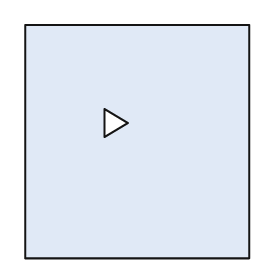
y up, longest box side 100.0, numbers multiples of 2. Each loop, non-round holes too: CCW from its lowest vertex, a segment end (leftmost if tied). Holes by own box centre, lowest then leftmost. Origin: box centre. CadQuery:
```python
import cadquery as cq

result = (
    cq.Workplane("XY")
    .moveTo(-48.0, -50.0)
    .lineTo(48.0, -50.0)
    .lineTo(48.0, 50.0)
    .lineTo(-48.0, 50.0)
    .close()
    .moveTo(-14.0, 2.0)
    .lineTo(-4.0, 8.0)
    .lineTo(-14.0, 14.0)
    .close()
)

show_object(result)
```